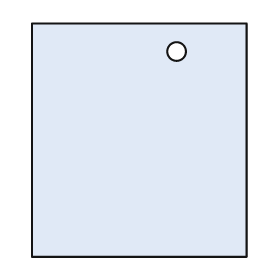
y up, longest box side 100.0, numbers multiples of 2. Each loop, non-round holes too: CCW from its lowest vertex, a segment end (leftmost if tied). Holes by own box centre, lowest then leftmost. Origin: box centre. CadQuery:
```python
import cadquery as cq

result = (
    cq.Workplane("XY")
    .moveTo(-46.0, -50.0)
    .lineTo(46.0, -50.0)
    .lineTo(46.0, 50.0)
    .lineTo(-46.0, 50.0)
    .close()
    .moveTo(16.0, 38.0)
    .circle(4.0)
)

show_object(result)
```